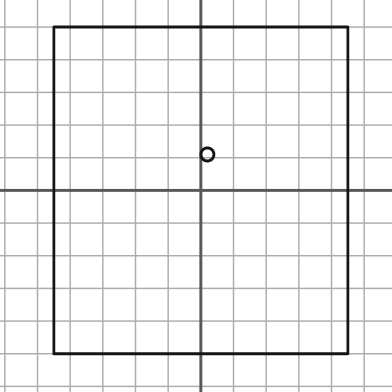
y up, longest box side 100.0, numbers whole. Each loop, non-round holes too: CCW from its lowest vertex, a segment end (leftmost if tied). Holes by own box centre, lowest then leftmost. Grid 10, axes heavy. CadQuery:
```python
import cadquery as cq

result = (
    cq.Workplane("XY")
    .moveTo(-45.0, -50.0)
    .lineTo(45.0, -50.0)
    .lineTo(45.0, 50.0)
    .lineTo(-45.0, 50.0)
    .close()
    .moveTo(2.0, 11.0)
    .circle(2.0)
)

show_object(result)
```